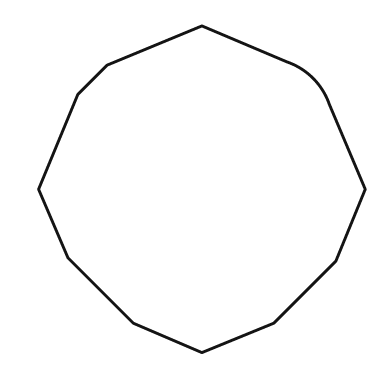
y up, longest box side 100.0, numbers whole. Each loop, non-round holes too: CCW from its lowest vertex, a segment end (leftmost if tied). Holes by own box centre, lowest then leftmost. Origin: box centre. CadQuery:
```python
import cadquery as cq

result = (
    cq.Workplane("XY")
    .moveTo(0.0, -50.0)
    .lineTo(22.0, -41.0)
    .lineTo(41.0, -22.0)
    .lineTo(50.0, 0.0)
    .lineTo(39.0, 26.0)
    .threePointArc((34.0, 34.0), (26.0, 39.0))
    .lineTo(0.0, 50.0)
    .lineTo(-29.0, 38.0)
    .lineTo(-38.0, 29.0)
    .lineTo(-50.0, 0.0)
    .lineTo(-41.0, -21.0)
    .lineTo(-21.0, -41.0)
    .close()
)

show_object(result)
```